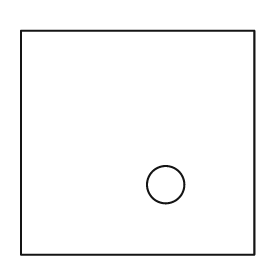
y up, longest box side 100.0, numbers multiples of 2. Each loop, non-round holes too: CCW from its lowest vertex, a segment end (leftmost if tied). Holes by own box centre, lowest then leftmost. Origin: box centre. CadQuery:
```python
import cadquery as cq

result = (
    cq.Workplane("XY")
    .moveTo(-50.0, -48.0)
    .lineTo(50.0, -48.0)
    .lineTo(50.0, 48.0)
    .lineTo(-50.0, 48.0)
    .close()
    .moveTo(12.0, -18.0)
    .circle(8.0)
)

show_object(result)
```